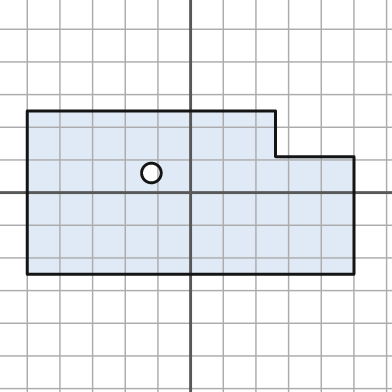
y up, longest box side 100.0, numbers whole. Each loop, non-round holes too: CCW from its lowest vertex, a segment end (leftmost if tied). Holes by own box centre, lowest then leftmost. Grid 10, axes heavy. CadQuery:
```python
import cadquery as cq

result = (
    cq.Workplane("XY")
    .moveTo(-50.0, -25.0)
    .lineTo(50.0, -25.0)
    .lineTo(50.0, 11.0)
    .lineTo(26.0, 11.0)
    .lineTo(26.0, 25.0)
    .lineTo(-50.0, 25.0)
    .close()
    .moveTo(-12.0, 6.0)
    .circle(3.0)
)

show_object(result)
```